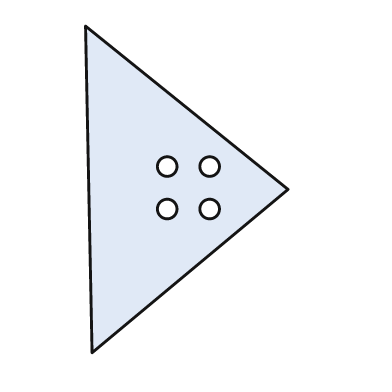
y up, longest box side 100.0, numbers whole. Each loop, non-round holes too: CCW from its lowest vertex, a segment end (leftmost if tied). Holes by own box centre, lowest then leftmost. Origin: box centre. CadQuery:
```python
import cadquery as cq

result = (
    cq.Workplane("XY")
    .moveTo(-29.0, -50.0)
    .lineTo(31.0, 0.0)
    .lineTo(-31.0, 50.0)
    .close()
    .moveTo(-6.0, -6.0)
    .circle(3.0)
    .moveTo(7.0, -6.0)
    .circle(3.0)
    .moveTo(-6.0, 7.0)
    .circle(3.0)
    .moveTo(7.0, 7.0)
    .circle(3.0)
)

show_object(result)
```